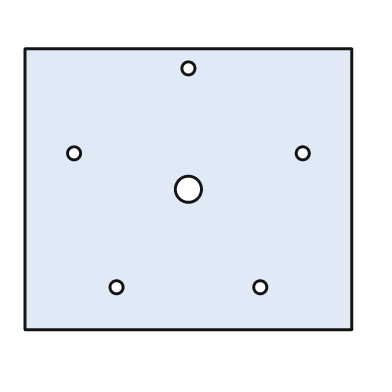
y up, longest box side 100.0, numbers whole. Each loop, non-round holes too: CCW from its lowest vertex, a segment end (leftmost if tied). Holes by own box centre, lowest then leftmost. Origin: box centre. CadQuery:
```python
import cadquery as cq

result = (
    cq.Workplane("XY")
    .moveTo(-50.0, -43.0)
    .lineTo(50.0, -43.0)
    .lineTo(50.0, 43.0)
    .lineTo(-50.0, 43.0)
    .close()
    .moveTo(-22.0, -30.0)
    .circle(2.0)
    .moveTo(22.0, -30.0)
    .circle(2.0)
    .moveTo(0.0, 0.0)
    .circle(4.0)
    .moveTo(-35.0, 11.0)
    .circle(2.0)
    .moveTo(35.0, 11.0)
    .circle(2.0)
    .moveTo(0.0, 37.0)
    .circle(2.0)
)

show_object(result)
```